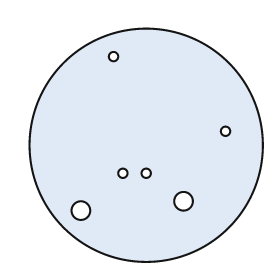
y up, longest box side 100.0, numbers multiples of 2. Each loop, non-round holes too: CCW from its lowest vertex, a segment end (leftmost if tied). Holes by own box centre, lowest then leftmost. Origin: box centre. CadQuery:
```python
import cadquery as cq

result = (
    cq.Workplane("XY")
    .moveTo(0.0, 0.0)
    .circle(50.0)
    .moveTo(-28.0, -28.0)
    .circle(4.0)
    .moveTo(16.0, -24.0)
    .circle(4.0)
    .moveTo(-10.0, -12.0)
    .circle(2.0)
    .moveTo(0.0, -12.0)
    .circle(2.0)
    .moveTo(34.0, 6.0)
    .circle(2.0)
    .moveTo(-14.0, 38.0)
    .circle(2.0)
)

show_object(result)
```